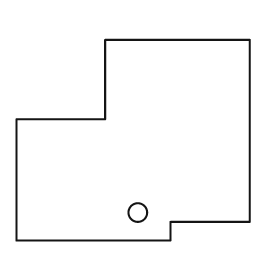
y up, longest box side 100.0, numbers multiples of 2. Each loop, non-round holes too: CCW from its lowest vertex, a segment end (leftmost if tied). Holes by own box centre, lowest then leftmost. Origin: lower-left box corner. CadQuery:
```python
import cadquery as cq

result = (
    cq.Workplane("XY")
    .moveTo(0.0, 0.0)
    .lineTo(66.0, 0.0)
    .lineTo(66.0, 8.0)
    .lineTo(100.0, 8.0)
    .lineTo(100.0, 86.0)
    .lineTo(38.0, 86.0)
    .lineTo(38.0, 52.0)
    .lineTo(0.0, 52.0)
    .close()
    .moveTo(52.0, 12.0)
    .circle(4.0)
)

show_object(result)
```